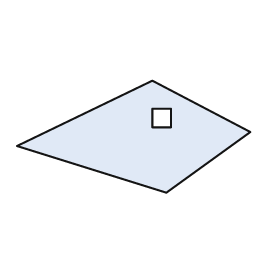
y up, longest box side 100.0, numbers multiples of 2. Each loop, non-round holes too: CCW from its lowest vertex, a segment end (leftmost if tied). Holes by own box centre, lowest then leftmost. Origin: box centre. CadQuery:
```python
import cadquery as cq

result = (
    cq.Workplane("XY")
    .moveTo(14.0, -24.0)
    .lineTo(50.0, 2.0)
    .lineTo(8.0, 24.0)
    .lineTo(-50.0, -4.0)
    .close()
    .moveTo(8.0, 4.0)
    .lineTo(16.0, 4.0)
    .lineTo(16.0, 12.0)
    .lineTo(8.0, 12.0)
    .close()
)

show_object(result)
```